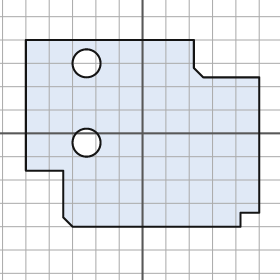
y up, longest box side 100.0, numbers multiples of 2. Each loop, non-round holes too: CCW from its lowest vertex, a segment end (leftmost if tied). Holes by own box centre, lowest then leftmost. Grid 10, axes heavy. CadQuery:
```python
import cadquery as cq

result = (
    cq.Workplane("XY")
    .moveTo(-30.0, -40.0)
    .lineTo(42.0, -40.0)
    .lineTo(42.0, -34.0)
    .lineTo(50.0, -34.0)
    .lineTo(50.0, 24.0)
    .lineTo(26.0, 24.0)
    .lineTo(22.0, 28.0)
    .lineTo(22.0, 40.0)
    .lineTo(-50.0, 40.0)
    .lineTo(-50.0, -16.0)
    .lineTo(-34.0, -16.0)
    .lineTo(-34.0, -36.0)
    .close()
    .moveTo(-24.0, -4.0)
    .circle(6.0)
    .moveTo(-24.0, 30.0)
    .circle(6.0)
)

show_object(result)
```